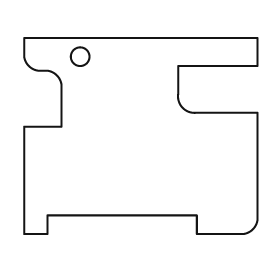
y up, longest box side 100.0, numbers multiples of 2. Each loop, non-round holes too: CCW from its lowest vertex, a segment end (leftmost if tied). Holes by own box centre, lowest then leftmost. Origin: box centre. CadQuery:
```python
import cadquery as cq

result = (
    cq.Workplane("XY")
    .moveTo(-50.0, -42.0)
    .lineTo(-40.0, -42.0)
    .lineTo(-40.0, -34.0)
    .lineTo(24.0, -34.0)
    .lineTo(24.0, -42.0)
    .lineTo(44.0, -42.0)
    .threePointArc((48.0, -40.0), (50.0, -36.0))
    .lineTo(50.0, 10.0)
    .lineTo(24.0, 10.0)
    .threePointArc((18.0, 12.0), (16.0, 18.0))
    .lineTo(16.0, 30.0)
    .lineTo(50.0, 30.0)
    .lineTo(50.0, 42.0)
    .lineTo(-50.0, 42.0)
    .lineTo(-50.0, 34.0)
    .threePointArc((-48.0, 30.0), (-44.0, 28.0))
    .lineTo(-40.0, 28.0)
    .threePointArc((-36.0, 26.0), (-34.0, 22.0))
    .lineTo(-34.0, 4.0)
    .lineTo(-50.0, 4.0)
    .close()
    .moveTo(-26.0, 34.0)
    .circle(4.0)
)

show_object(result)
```